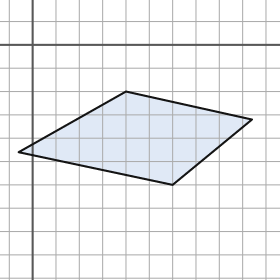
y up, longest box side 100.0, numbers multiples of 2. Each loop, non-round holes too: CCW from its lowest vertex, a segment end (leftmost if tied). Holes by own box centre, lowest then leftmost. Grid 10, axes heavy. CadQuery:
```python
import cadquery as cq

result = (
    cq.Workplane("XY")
    .moveTo(60.0, -60.0)
    .lineTo(94.0, -32.0)
    .lineTo(40.0, -20.0)
    .lineTo(-6.0, -46.0)
    .close()
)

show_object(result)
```